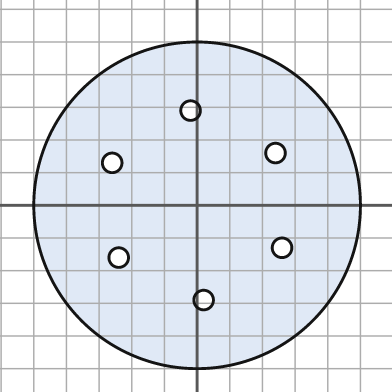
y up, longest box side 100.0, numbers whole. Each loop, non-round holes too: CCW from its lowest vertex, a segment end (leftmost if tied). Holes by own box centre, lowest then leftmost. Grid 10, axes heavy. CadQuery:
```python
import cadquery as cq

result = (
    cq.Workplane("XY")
    .moveTo(0.0, 0.0)
    .circle(50.0)
    .moveTo(2.0, -29.0)
    .circle(3.0)
    .moveTo(-24.0, -16.0)
    .circle(3.0)
    .moveTo(26.0, -13.0)
    .circle(3.0)
    .moveTo(-26.0, 13.0)
    .circle(3.0)
    .moveTo(24.0, 16.0)
    .circle(3.0)
    .moveTo(-2.0, 29.0)
    .circle(3.0)
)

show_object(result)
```